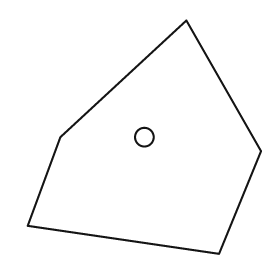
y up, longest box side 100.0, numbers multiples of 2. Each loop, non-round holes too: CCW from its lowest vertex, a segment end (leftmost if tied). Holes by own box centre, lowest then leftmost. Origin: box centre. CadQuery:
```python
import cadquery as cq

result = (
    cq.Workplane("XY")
    .moveTo(32.0, -50.0)
    .lineTo(50.0, -6.0)
    .lineTo(18.0, 50.0)
    .lineTo(-36.0, 0.0)
    .lineTo(-50.0, -38.0)
    .close()
    .moveTo(0.0, 0.0)
    .circle(4.0)
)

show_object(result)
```